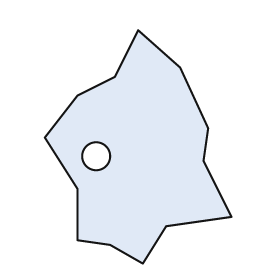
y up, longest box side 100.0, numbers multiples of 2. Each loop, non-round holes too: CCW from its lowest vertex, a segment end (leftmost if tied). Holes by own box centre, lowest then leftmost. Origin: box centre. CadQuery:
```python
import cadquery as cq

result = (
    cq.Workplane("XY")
    .moveTo(2.0, -50.0)
    .lineTo(12.0, -34.0)
    .lineTo(40.0, -30.0)
    .lineTo(28.0, -6.0)
    .lineTo(30.0, 8.0)
    .lineTo(18.0, 34.0)
    .lineTo(0.0, 50.0)
    .lineTo(-10.0, 30.0)
    .lineTo(-26.0, 22.0)
    .lineTo(-40.0, 4.0)
    .lineTo(-26.0, -18.0)
    .lineTo(-26.0, -40.0)
    .lineTo(-12.0, -42.0)
    .close()
    .moveTo(-18.0, -4.0)
    .circle(6.0)
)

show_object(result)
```